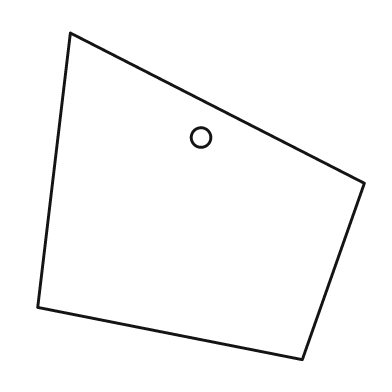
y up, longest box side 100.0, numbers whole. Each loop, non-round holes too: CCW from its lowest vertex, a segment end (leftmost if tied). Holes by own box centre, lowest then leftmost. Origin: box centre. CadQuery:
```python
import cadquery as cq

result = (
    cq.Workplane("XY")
    .moveTo(31.0, -50.0)
    .lineTo(50.0, 4.0)
    .lineTo(-40.0, 50.0)
    .lineTo(-50.0, -34.0)
    .close()
    .moveTo(0.0, 18.0)
    .circle(3.0)
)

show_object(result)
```